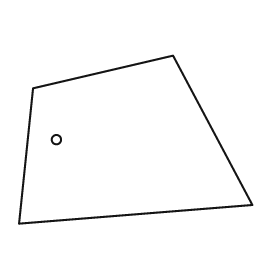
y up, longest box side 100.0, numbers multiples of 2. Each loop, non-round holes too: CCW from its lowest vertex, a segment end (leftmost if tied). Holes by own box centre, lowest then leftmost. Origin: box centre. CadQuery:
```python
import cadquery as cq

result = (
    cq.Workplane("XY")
    .moveTo(-50.0, -36.0)
    .lineTo(50.0, -28.0)
    .lineTo(16.0, 36.0)
    .lineTo(-44.0, 22.0)
    .close()
    .moveTo(-34.0, 0.0)
    .circle(2.0)
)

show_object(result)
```